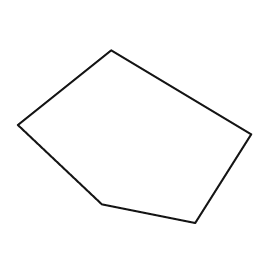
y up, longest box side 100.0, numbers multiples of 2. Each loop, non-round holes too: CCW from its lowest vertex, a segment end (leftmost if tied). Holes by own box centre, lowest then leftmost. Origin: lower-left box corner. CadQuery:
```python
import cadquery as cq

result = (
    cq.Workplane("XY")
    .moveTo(76.0, 0.0)
    .lineTo(100.0, 38.0)
    .lineTo(40.0, 74.0)
    .lineTo(0.0, 42.0)
    .lineTo(36.0, 8.0)
    .close()
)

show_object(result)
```